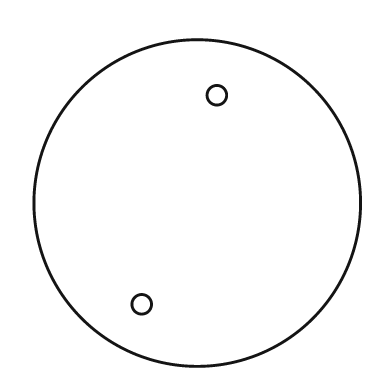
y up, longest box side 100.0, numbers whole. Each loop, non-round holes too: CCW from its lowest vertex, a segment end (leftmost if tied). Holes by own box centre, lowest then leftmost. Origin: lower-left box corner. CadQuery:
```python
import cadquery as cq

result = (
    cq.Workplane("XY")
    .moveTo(50.0, 50.0)
    .circle(50.0)
    .moveTo(33.0, 19.0)
    .circle(3.0)
    .moveTo(56.0, 83.0)
    .circle(3.0)
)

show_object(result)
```